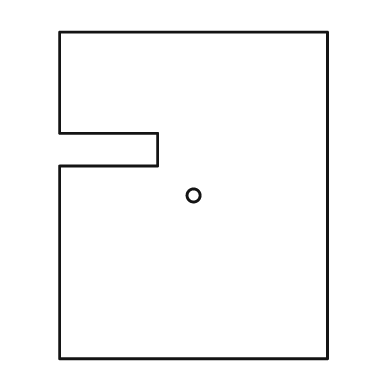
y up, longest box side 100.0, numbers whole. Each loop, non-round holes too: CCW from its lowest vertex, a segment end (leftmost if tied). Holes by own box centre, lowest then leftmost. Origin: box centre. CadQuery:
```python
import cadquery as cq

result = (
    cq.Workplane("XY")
    .moveTo(-41.0, -50.0)
    .lineTo(41.0, -50.0)
    .lineTo(41.0, 50.0)
    .lineTo(-41.0, 50.0)
    .lineTo(-41.0, 19.0)
    .lineTo(-11.0, 19.0)
    .lineTo(-11.0, 9.0)
    .lineTo(-41.0, 9.0)
    .close()
    .moveTo(0.0, 0.0)
    .circle(2.0)
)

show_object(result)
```